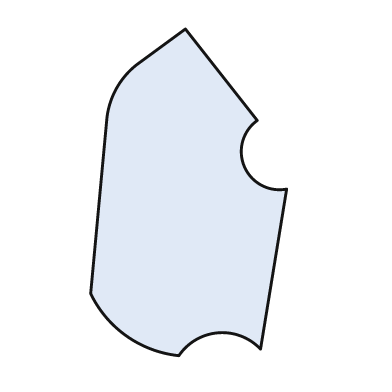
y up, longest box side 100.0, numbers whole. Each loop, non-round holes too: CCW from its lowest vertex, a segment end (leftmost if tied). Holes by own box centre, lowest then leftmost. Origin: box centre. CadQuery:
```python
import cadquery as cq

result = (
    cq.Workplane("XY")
    .moveTo(-3.0, -50.0)
    .threePointArc((9.0, -43.0), (22.0, -48.0))
    .lineTo(30.0, 1.0)
    .threePointArc((17.0, 8.0), (21.0, 22.0))
    .lineTo(-1.0, 50.0)
    .lineTo(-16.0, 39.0)
    .threePointArc((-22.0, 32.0), (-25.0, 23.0))
    .lineTo(-30.0, -31.0)
    .threePointArc((-19.0, -44.0), (-3.0, -50.0))
    .close()
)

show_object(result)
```